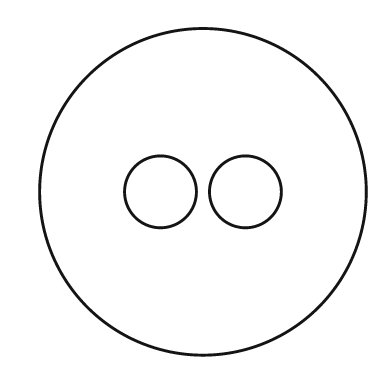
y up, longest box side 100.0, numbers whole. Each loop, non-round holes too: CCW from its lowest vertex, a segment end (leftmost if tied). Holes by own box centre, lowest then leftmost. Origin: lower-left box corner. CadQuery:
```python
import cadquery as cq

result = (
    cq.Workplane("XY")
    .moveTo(50.0, 50.0)
    .circle(50.0)
    .moveTo(37.0, 50.0)
    .circle(11.0)
    .moveTo(63.0, 50.0)
    .circle(11.0)
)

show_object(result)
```